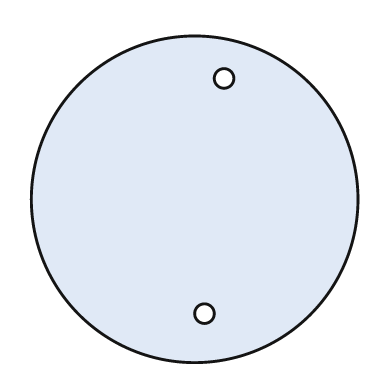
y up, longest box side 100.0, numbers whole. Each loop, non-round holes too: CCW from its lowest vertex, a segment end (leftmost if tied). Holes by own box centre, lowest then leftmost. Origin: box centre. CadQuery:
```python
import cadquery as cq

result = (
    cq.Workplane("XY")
    .moveTo(0.0, 0.0)
    .circle(50.0)
    .moveTo(3.0, -35.0)
    .circle(3.0)
    .moveTo(9.0, 37.0)
    .circle(3.0)
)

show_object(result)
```